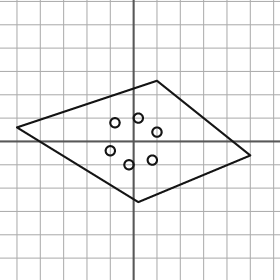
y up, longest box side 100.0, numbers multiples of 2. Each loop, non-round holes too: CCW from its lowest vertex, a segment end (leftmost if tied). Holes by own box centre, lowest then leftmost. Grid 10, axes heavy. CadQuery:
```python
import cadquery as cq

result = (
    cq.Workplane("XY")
    .moveTo(2.0, -26.0)
    .lineTo(50.0, -6.0)
    .lineTo(10.0, 26.0)
    .lineTo(-50.0, 6.0)
    .close()
    .moveTo(-2.0, -10.0)
    .circle(2.0)
    .moveTo(8.0, -8.0)
    .circle(2.0)
    .moveTo(-10.0, -4.0)
    .circle(2.0)
    .moveTo(10.0, 4.0)
    .circle(2.0)
    .moveTo(-8.0, 8.0)
    .circle(2.0)
    .moveTo(2.0, 10.0)
    .circle(2.0)
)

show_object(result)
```